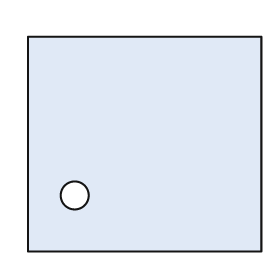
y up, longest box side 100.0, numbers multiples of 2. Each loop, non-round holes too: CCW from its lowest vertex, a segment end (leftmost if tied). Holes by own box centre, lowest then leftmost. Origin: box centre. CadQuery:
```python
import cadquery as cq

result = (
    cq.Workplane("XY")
    .moveTo(-50.0, -46.0)
    .lineTo(50.0, -46.0)
    .lineTo(50.0, 46.0)
    .lineTo(-50.0, 46.0)
    .close()
    .moveTo(-30.0, -22.0)
    .circle(6.0)
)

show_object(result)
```